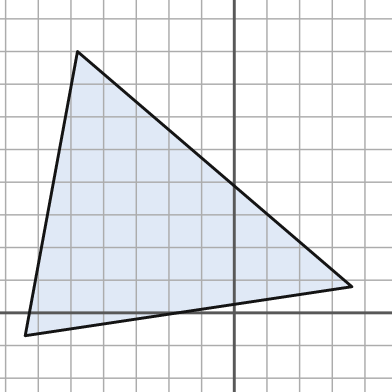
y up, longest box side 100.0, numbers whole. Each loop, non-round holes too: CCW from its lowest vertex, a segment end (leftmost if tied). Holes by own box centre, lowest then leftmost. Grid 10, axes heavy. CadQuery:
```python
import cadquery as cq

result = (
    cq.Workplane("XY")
    .moveTo(-64.0, -7.0)
    .lineTo(36.0, 8.0)
    .lineTo(-48.0, 80.0)
    .close()
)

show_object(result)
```